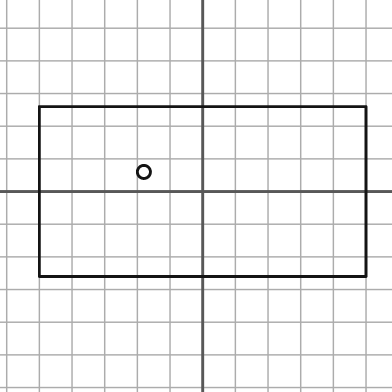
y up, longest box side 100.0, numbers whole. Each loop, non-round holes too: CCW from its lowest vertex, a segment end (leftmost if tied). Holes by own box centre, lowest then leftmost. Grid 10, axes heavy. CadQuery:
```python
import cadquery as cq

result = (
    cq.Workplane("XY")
    .moveTo(-50.0, -26.0)
    .lineTo(50.0, -26.0)
    .lineTo(50.0, 26.0)
    .lineTo(-50.0, 26.0)
    .close()
    .moveTo(-18.0, 6.0)
    .circle(2.0)
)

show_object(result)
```